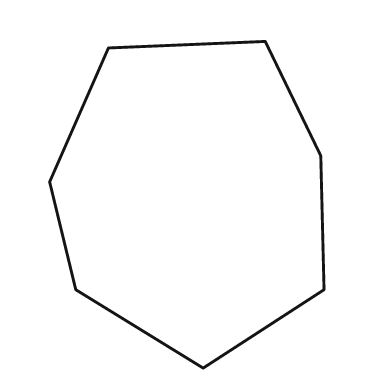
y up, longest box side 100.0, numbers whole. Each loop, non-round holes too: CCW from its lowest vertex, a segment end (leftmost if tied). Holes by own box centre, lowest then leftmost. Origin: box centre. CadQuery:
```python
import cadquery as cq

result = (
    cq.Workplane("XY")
    .moveTo(5.0, -50.0)
    .lineTo(42.0, -26.0)
    .lineTo(41.0, 15.0)
    .lineTo(24.0, 50.0)
    .lineTo(-24.0, 48.0)
    .lineTo(-42.0, 7.0)
    .lineTo(-34.0, -26.0)
    .close()
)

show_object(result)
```